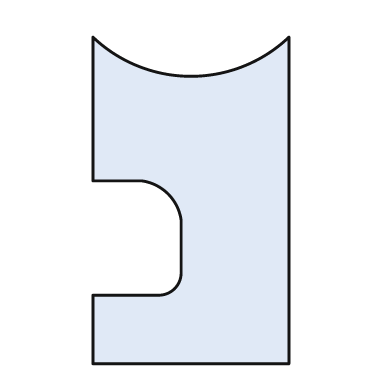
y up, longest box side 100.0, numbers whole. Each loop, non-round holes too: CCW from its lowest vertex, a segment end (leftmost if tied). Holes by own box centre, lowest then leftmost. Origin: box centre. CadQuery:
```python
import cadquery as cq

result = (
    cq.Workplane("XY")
    .moveTo(-30.0, -50.0)
    .lineTo(30.0, -50.0)
    .lineTo(30.0, 50.0)
    .threePointArc((0.0, 38.0), (-30.0, 50.0))
    .lineTo(-30.0, 6.0)
    .lineTo(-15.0, 6.0)
    .threePointArc((-7.0, 2.0), (-3.0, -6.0))
    .lineTo(-3.0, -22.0)
    .threePointArc((-5.0, -27.0), (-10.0, -29.0))
    .lineTo(-30.0, -29.0)
    .close()
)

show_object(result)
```